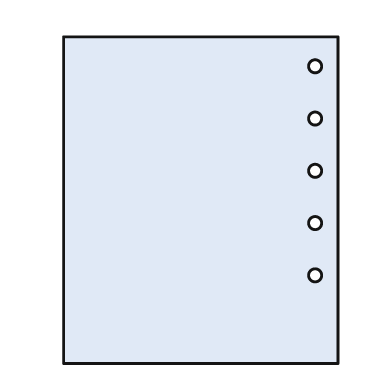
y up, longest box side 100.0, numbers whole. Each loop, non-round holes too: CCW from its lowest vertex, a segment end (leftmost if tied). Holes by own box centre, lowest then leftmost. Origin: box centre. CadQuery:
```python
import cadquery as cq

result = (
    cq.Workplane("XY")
    .moveTo(-42.0, -50.0)
    .lineTo(42.0, -50.0)
    .lineTo(42.0, 50.0)
    .lineTo(-42.0, 50.0)
    .close()
    .moveTo(35.0, -23.0)
    .circle(2.0)
    .moveTo(35.0, -7.0)
    .circle(2.0)
    .moveTo(35.0, 9.0)
    .circle(2.0)
    .moveTo(35.0, 25.0)
    .circle(2.0)
    .moveTo(35.0, 41.0)
    .circle(2.0)
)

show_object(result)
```